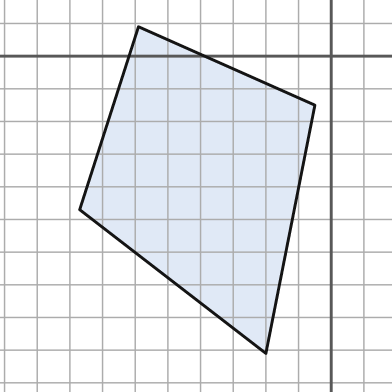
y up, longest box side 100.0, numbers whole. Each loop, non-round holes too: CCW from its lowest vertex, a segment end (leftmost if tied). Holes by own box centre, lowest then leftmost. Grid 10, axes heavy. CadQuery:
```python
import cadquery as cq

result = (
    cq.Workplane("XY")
    .moveTo(-20.0, -91.0)
    .lineTo(-5.0, -15.0)
    .lineTo(-59.0, 9.0)
    .lineTo(-77.0, -47.0)
    .close()
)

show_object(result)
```